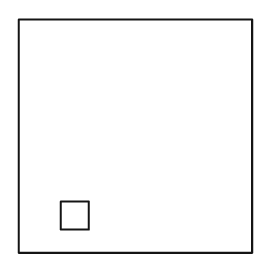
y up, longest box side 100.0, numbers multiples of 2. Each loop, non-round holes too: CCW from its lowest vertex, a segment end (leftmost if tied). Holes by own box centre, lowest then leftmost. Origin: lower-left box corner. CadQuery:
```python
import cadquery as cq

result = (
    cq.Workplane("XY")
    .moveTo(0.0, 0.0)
    .lineTo(100.0, 0.0)
    .lineTo(100.0, 100.0)
    .lineTo(0.0, 100.0)
    .close()
    .moveTo(18.0, 10.0)
    .lineTo(30.0, 10.0)
    .lineTo(30.0, 22.0)
    .lineTo(18.0, 22.0)
    .close()
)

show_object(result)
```